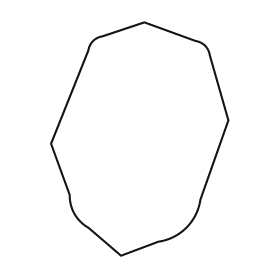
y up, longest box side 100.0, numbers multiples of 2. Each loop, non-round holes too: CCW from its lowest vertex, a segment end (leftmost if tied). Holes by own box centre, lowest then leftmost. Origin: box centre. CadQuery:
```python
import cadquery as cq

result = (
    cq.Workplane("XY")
    .moveTo(-8.0, -50.0)
    .lineTo(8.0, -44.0)
    .threePointArc((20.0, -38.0), (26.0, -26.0))
    .lineTo(38.0, 8.0)
    .lineTo(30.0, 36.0)
    .threePointArc((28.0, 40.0), (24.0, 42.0))
    .lineTo(2.0, 50.0)
    .lineTo(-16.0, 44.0)
    .threePointArc((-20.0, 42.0), (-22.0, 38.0))
    .lineTo(-38.0, -2.0)
    .lineTo(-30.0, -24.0)
    .threePointArc((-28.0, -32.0), (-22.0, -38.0))
    .close()
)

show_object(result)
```